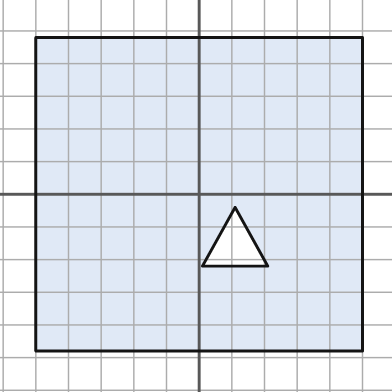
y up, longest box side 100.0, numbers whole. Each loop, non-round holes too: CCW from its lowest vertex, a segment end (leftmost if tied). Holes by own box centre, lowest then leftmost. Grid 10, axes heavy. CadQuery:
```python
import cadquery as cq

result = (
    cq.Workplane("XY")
    .moveTo(-50.0, -48.0)
    .lineTo(50.0, -48.0)
    .lineTo(50.0, 48.0)
    .lineTo(-50.0, 48.0)
    .close()
    .moveTo(1.0, -22.0)
    .lineTo(21.0, -22.0)
    .lineTo(11.0, -4.0)
    .close()
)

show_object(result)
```